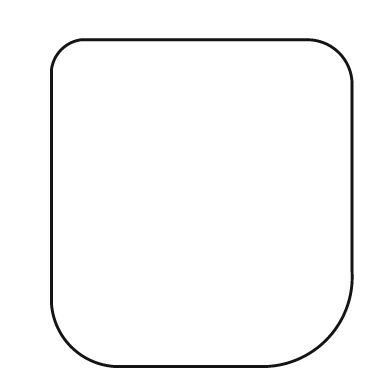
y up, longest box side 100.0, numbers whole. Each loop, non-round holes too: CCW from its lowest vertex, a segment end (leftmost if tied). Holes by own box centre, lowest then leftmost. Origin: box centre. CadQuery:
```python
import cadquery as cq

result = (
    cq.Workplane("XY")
    .moveTo(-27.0, -50.0)
    .lineTo(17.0, -50.0)
    .threePointArc((38.0, -42.0), (46.0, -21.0))
    .lineTo(46.0, 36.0)
    .threePointArc((42.0, 46.0), (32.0, 50.0))
    .lineTo(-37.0, 50.0)
    .threePointArc((-43.0, 47.0), (-46.0, 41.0))
    .lineTo(-46.0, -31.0)
    .threePointArc((-40.0, -44.0), (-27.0, -50.0))
    .close()
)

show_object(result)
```